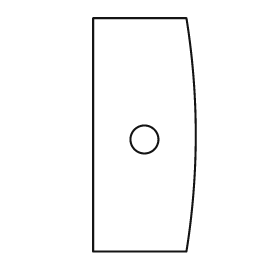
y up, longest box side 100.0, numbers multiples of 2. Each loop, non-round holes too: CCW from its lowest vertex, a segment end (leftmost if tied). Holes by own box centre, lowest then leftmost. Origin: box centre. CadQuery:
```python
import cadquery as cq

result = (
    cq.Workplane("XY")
    .moveTo(-22.0, -50.0)
    .lineTo(18.0, -50.0)
    .threePointArc((22.0, 0.0), (18.0, 50.0))
    .lineTo(-22.0, 50.0)
    .close()
    .moveTo(0.0, -2.0)
    .circle(6.0)
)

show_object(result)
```